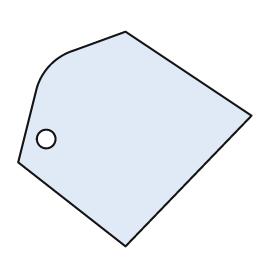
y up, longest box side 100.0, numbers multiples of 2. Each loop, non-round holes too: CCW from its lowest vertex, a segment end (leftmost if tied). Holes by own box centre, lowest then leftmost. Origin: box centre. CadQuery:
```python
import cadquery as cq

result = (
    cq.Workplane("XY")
    .moveTo(-4.0, -46.0)
    .lineTo(50.0, 10.0)
    .lineTo(-4.0, 46.0)
    .lineTo(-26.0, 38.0)
    .threePointArc((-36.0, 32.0), (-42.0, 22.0))
    .lineTo(-50.0, -10.0)
    .close()
    .moveTo(-38.0, 0.0)
    .circle(4.0)
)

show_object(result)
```